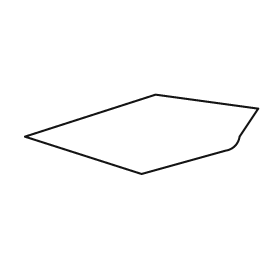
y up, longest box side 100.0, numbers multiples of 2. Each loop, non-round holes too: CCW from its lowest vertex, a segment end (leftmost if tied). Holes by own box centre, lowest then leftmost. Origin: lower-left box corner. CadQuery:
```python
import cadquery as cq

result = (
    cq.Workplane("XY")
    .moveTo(50.0, 0.0)
    .lineTo(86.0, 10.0)
    .threePointArc((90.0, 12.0), (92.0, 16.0))
    .lineTo(100.0, 28.0)
    .lineTo(56.0, 34.0)
    .lineTo(0.0, 16.0)
    .close()
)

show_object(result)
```